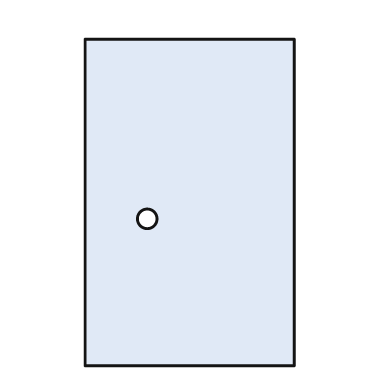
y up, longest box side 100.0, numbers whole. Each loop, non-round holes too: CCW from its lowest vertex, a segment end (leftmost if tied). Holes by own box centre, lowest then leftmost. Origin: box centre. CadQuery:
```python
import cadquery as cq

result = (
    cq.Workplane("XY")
    .moveTo(-32.0, -50.0)
    .lineTo(32.0, -50.0)
    .lineTo(32.0, 50.0)
    .lineTo(-32.0, 50.0)
    .close()
    .moveTo(-13.0, -5.0)
    .circle(3.0)
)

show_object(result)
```